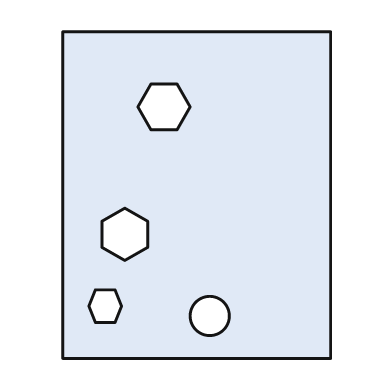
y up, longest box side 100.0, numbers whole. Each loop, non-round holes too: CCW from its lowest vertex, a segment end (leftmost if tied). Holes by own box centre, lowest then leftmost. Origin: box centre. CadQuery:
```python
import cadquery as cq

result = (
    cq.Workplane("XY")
    .moveTo(-41.0, -50.0)
    .lineTo(41.0, -50.0)
    .lineTo(41.0, 50.0)
    .lineTo(-41.0, 50.0)
    .close()
    .moveTo(4.0, -37.0)
    .circle(6.0)
    .moveTo(-31.0, -39.0)
    .lineTo(-25.0, -39.0)
    .lineTo(-23.0, -34.0)
    .lineTo(-25.0, -29.0)
    .lineTo(-31.0, -29.0)
    .lineTo(-33.0, -34.0)
    .close()
    .moveTo(-22.0, -20.0)
    .lineTo(-15.0, -16.0)
    .lineTo(-15.0, -8.0)
    .lineTo(-22.0, -4.0)
    .lineTo(-29.0, -8.0)
    .lineTo(-29.0, -16.0)
    .close()
    .moveTo(-14.0, 20.0)
    .lineTo(-6.0, 20.0)
    .lineTo(-2.0, 27.0)
    .lineTo(-6.0, 34.0)
    .lineTo(-14.0, 34.0)
    .lineTo(-18.0, 27.0)
    .close()
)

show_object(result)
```